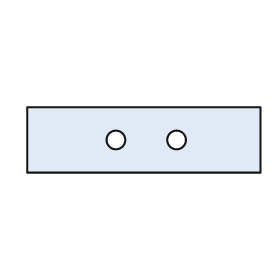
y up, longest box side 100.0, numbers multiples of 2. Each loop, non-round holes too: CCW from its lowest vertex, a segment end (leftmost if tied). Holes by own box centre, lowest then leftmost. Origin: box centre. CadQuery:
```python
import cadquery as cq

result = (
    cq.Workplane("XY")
    .moveTo(-50.0, -14.0)
    .lineTo(50.0, -14.0)
    .lineTo(50.0, 14.0)
    .lineTo(-50.0, 14.0)
    .close()
    .moveTo(-12.0, 0.0)
    .circle(4.0)
    .moveTo(14.0, 0.0)
    .circle(4.0)
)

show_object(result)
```